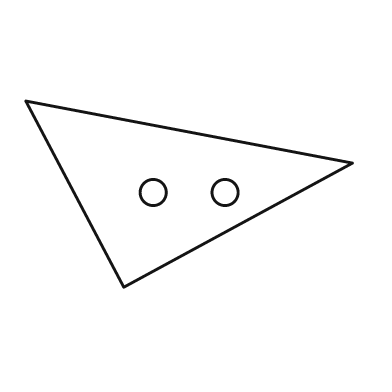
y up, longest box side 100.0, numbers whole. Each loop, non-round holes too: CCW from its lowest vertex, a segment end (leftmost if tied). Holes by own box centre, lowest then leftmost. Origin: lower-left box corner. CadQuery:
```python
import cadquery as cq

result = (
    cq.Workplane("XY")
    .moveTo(30.0, 0.0)
    .lineTo(100.0, 38.0)
    .lineTo(0.0, 57.0)
    .close()
    .moveTo(39.0, 29.0)
    .circle(4.0)
    .moveTo(61.0, 29.0)
    .circle(4.0)
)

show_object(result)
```